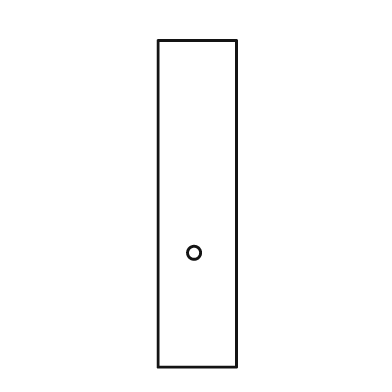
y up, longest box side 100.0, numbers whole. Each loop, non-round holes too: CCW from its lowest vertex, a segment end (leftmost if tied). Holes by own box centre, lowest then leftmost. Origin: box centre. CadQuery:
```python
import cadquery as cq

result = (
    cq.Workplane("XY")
    .moveTo(-12.0, -50.0)
    .lineTo(12.0, -50.0)
    .lineTo(12.0, 50.0)
    .lineTo(-12.0, 50.0)
    .close()
    .moveTo(-1.0, -15.0)
    .circle(2.0)
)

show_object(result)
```